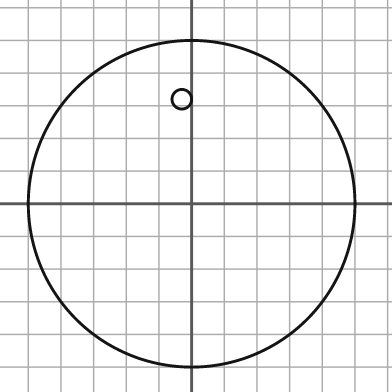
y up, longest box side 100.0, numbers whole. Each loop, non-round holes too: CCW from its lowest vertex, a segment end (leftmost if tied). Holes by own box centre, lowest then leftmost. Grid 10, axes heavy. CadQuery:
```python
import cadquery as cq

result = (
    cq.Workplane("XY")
    .moveTo(0.0, 0.0)
    .circle(50.0)
    .moveTo(-3.0, 32.0)
    .circle(3.0)
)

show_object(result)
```